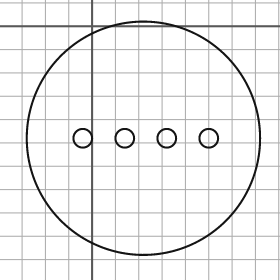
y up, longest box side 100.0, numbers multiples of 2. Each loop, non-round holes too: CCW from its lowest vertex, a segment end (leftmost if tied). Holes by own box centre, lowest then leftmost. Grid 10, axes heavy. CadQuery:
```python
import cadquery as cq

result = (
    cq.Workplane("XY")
    .moveTo(22.0, -48.0)
    .circle(50.0)
    .moveTo(-4.0, -48.0)
    .circle(4.0)
    .moveTo(14.0, -48.0)
    .circle(4.0)
    .moveTo(32.0, -48.0)
    .circle(4.0)
    .moveTo(50.0, -48.0)
    .circle(4.0)
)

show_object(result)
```